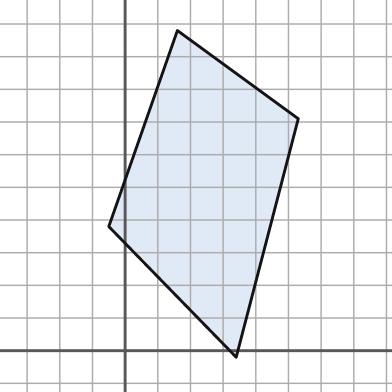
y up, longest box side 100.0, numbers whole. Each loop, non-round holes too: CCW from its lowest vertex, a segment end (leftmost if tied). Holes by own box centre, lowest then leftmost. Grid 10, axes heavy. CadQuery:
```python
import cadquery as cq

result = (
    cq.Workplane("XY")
    .moveTo(34.0, -2.0)
    .lineTo(53.0, 71.0)
    .lineTo(16.0, 98.0)
    .lineTo(-5.0, 38.0)
    .close()
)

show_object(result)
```